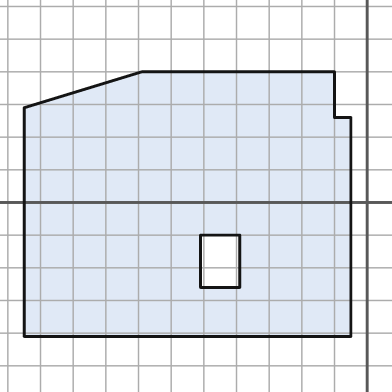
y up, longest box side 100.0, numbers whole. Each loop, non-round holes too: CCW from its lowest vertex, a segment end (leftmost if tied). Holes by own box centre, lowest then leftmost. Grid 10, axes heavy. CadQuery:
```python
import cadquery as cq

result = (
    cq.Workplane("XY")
    .moveTo(-105.0, -41.0)
    .lineTo(-5.0, -41.0)
    .lineTo(-5.0, 26.0)
    .lineTo(-10.0, 26.0)
    .lineTo(-10.0, 40.0)
    .lineTo(-69.0, 40.0)
    .lineTo(-105.0, 29.0)
    .close()
    .moveTo(-51.0, -26.0)
    .lineTo(-39.0, -26.0)
    .lineTo(-39.0, -10.0)
    .lineTo(-51.0, -10.0)
    .close()
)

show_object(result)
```